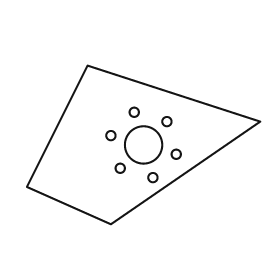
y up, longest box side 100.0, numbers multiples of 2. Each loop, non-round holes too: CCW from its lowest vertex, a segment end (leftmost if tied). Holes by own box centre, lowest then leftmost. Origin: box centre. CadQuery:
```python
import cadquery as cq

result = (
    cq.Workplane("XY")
    .moveTo(-14.0, -34.0)
    .lineTo(50.0, 10.0)
    .lineTo(-24.0, 34.0)
    .lineTo(-50.0, -18.0)
    .close()
    .moveTo(4.0, -14.0)
    .circle(2.0)
    .moveTo(-10.0, -10.0)
    .circle(2.0)
    .moveTo(14.0, -4.0)
    .circle(2.0)
    .moveTo(0.0, 0.0)
    .circle(8.0)
    .moveTo(-14.0, 4.0)
    .circle(2.0)
    .moveTo(10.0, 10.0)
    .circle(2.0)
    .moveTo(-4.0, 14.0)
    .circle(2.0)
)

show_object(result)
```